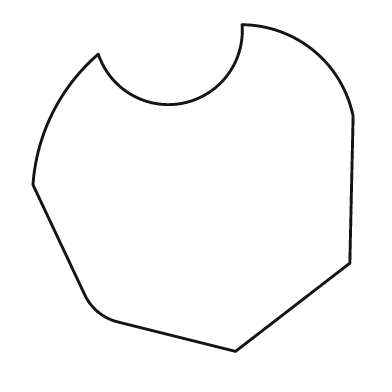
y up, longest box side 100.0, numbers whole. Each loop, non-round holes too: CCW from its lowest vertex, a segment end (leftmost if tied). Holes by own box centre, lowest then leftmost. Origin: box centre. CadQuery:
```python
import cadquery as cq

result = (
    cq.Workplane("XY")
    .moveTo(13.0, -50.0)
    .lineTo(48.0, -23.0)
    .lineTo(49.0, 22.0)
    .threePointArc((37.0, 42.0), (15.0, 50.0))
    .threePointArc((-3.0, 26.0), (-29.0, 41.0))
    .threePointArc((-43.0, 23.0), (-49.0, 1.0))
    .lineTo(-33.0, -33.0)
    .threePointArc((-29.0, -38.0), (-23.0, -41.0))
    .close()
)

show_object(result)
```